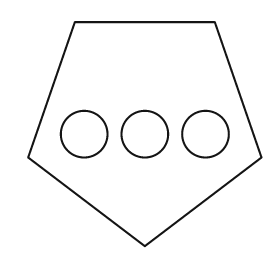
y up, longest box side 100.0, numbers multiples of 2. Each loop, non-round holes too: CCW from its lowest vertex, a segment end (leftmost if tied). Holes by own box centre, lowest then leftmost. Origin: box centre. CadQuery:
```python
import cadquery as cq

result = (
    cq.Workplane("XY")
    .moveTo(0.0, -48.0)
    .lineTo(50.0, -10.0)
    .lineTo(30.0, 48.0)
    .lineTo(-30.0, 48.0)
    .lineTo(-50.0, -10.0)
    .close()
    .moveTo(-26.0, 0.0)
    .circle(10.0)
    .moveTo(0.0, 0.0)
    .circle(10.0)
    .moveTo(26.0, 0.0)
    .circle(10.0)
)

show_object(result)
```